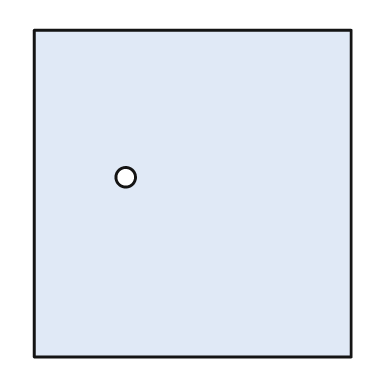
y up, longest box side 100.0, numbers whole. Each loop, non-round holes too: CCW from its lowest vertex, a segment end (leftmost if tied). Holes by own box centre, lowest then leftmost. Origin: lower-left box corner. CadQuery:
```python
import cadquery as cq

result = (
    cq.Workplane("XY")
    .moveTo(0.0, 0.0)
    .lineTo(97.0, 0.0)
    .lineTo(97.0, 100.0)
    .lineTo(0.0, 100.0)
    .close()
    .moveTo(28.0, 55.0)
    .circle(3.0)
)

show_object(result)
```